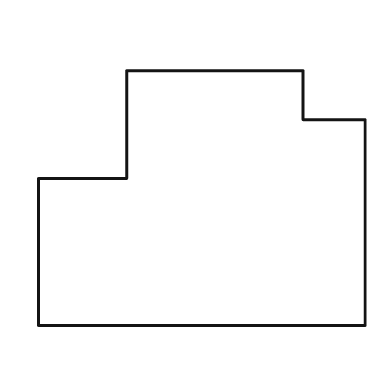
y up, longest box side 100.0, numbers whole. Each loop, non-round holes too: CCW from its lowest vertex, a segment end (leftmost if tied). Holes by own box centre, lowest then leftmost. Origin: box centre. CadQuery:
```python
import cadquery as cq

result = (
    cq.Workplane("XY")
    .moveTo(-50.0, -39.0)
    .lineTo(50.0, -39.0)
    .lineTo(50.0, 24.0)
    .lineTo(31.0, 24.0)
    .lineTo(31.0, 39.0)
    .lineTo(-23.0, 39.0)
    .lineTo(-23.0, 6.0)
    .lineTo(-50.0, 6.0)
    .close()
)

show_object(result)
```